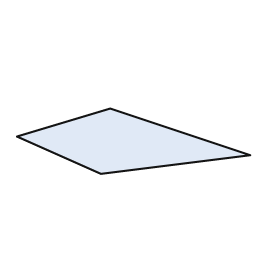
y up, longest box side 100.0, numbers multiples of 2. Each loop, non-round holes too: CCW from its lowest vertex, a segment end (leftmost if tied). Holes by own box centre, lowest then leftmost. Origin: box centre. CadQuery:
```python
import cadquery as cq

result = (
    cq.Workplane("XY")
    .moveTo(-14.0, -14.0)
    .lineTo(50.0, -6.0)
    .lineTo(-10.0, 14.0)
    .lineTo(-50.0, 2.0)
    .close()
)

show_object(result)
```